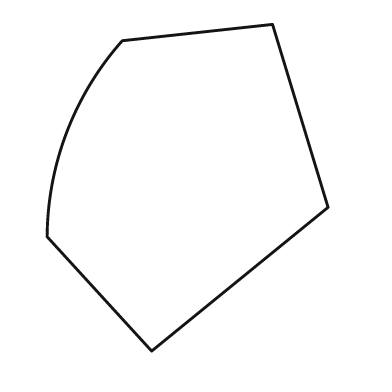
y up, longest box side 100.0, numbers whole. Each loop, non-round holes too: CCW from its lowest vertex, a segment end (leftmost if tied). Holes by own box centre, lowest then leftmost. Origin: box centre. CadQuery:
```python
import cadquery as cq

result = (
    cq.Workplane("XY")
    .moveTo(-11.0, -50.0)
    .lineTo(43.0, -6.0)
    .lineTo(26.0, 50.0)
    .lineTo(-20.0, 45.0)
    .threePointArc((-37.0, 17.0), (-43.0, -15.0))
    .close()
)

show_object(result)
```